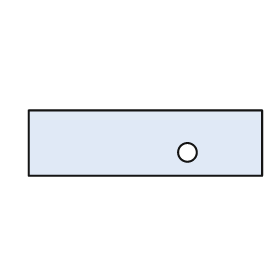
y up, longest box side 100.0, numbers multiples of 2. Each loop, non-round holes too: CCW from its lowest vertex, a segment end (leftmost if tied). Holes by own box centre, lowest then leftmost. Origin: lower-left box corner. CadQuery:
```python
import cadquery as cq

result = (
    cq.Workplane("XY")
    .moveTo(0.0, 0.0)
    .lineTo(100.0, 0.0)
    .lineTo(100.0, 28.0)
    .lineTo(0.0, 28.0)
    .close()
    .moveTo(68.0, 10.0)
    .circle(4.0)
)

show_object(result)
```